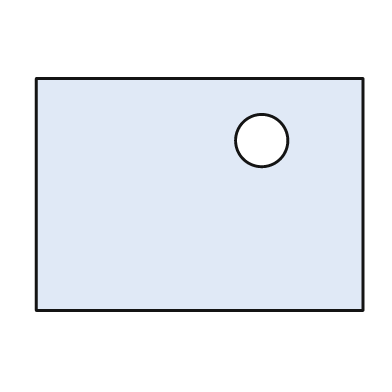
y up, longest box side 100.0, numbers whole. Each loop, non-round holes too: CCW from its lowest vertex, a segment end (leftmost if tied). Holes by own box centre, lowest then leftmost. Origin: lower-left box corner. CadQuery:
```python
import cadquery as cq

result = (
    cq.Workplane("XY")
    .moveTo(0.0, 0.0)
    .lineTo(100.0, 0.0)
    .lineTo(100.0, 71.0)
    .lineTo(0.0, 71.0)
    .close()
    .moveTo(69.0, 52.0)
    .circle(8.0)
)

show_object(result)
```